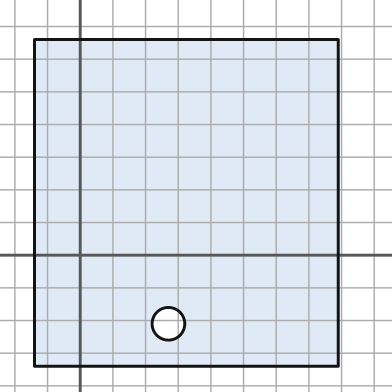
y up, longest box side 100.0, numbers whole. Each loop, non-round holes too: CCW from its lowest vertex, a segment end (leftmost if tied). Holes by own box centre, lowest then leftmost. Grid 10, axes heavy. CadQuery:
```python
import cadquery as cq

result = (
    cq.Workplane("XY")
    .moveTo(-14.0, -34.0)
    .lineTo(79.0, -34.0)
    .lineTo(79.0, 66.0)
    .lineTo(-14.0, 66.0)
    .close()
    .moveTo(27.0, -21.0)
    .circle(5.0)
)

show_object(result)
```